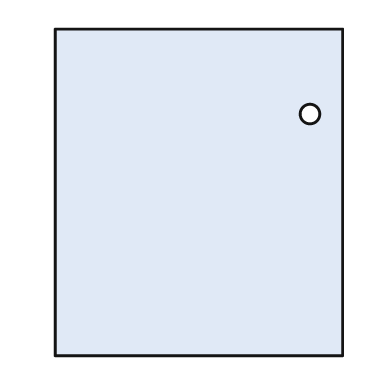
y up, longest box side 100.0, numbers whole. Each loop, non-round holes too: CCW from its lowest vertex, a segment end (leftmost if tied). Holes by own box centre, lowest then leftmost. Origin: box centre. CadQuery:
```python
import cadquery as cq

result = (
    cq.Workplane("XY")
    .moveTo(-44.0, -50.0)
    .lineTo(44.0, -50.0)
    .lineTo(44.0, 50.0)
    .lineTo(-44.0, 50.0)
    .close()
    .moveTo(34.0, 24.0)
    .circle(3.0)
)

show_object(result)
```